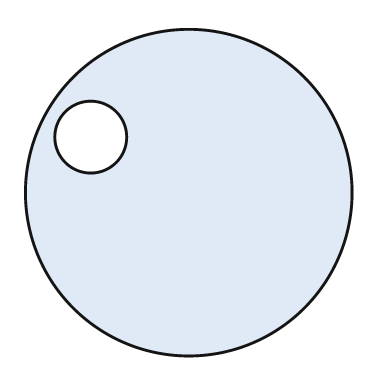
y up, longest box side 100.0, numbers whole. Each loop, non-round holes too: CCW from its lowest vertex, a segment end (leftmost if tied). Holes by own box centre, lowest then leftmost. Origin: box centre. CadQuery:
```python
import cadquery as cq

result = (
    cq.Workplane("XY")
    .moveTo(0.0, 0.0)
    .circle(50.0)
    .moveTo(-30.0, 17.0)
    .circle(11.0)
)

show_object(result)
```